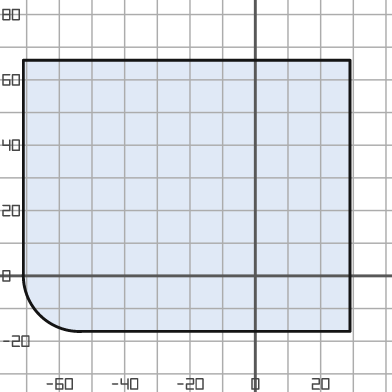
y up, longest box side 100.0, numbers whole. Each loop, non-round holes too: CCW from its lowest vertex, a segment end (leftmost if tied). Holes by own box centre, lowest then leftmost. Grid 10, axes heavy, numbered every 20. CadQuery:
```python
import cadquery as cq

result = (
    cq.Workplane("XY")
    .moveTo(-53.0, -17.0)
    .lineTo(29.0, -17.0)
    .lineTo(29.0, 66.0)
    .lineTo(-71.0, 66.0)
    .lineTo(-71.0, 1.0)
    .threePointArc((-66.0, -12.0), (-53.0, -17.0))
    .close()
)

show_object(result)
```